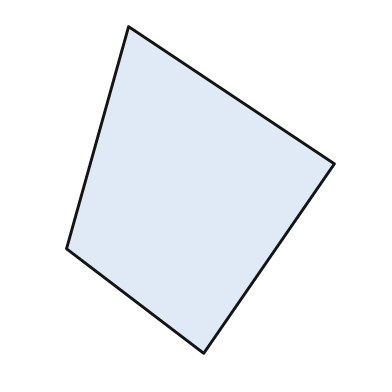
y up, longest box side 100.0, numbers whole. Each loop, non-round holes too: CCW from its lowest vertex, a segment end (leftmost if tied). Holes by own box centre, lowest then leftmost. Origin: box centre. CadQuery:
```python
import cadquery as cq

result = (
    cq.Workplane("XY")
    .moveTo(1.0, -50.0)
    .lineTo(41.0, 8.0)
    .lineTo(-22.0, 50.0)
    .lineTo(-41.0, -18.0)
    .close()
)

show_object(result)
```